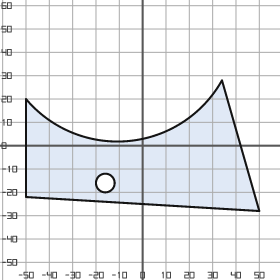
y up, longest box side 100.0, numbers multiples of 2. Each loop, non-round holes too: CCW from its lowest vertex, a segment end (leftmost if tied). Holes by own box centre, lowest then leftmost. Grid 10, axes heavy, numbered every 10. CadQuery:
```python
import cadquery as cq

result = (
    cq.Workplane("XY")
    .moveTo(50.0, -28.0)
    .lineTo(34.0, 28.0)
    .threePointArc((-6.0, 2.0), (-50.0, 20.0))
    .lineTo(-50.0, -22.0)
    .close()
    .moveTo(-16.0, -16.0)
    .circle(4.0)
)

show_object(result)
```